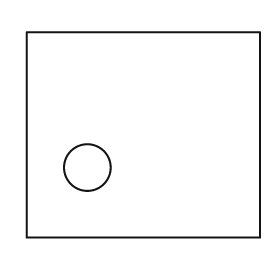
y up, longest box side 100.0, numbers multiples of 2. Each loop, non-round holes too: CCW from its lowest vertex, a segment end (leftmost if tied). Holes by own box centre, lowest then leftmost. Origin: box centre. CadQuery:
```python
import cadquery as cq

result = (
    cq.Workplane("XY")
    .moveTo(-50.0, -44.0)
    .lineTo(50.0, -44.0)
    .lineTo(50.0, 44.0)
    .lineTo(-50.0, 44.0)
    .close()
    .moveTo(-24.0, -14.0)
    .circle(10.0)
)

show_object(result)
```